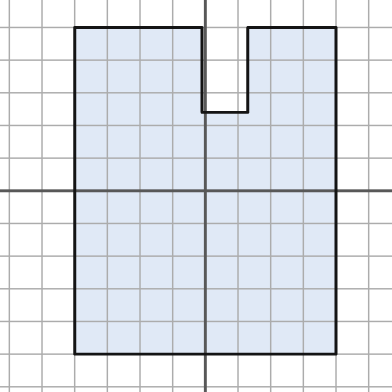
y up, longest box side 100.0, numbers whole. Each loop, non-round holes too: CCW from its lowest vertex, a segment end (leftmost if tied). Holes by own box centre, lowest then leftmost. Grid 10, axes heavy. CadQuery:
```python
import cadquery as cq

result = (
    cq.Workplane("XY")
    .moveTo(-40.0, -50.0)
    .lineTo(40.0, -50.0)
    .lineTo(40.0, 50.0)
    .lineTo(13.0, 50.0)
    .lineTo(13.0, 24.0)
    .lineTo(-1.0, 24.0)
    .lineTo(-1.0, 50.0)
    .lineTo(-40.0, 50.0)
    .close()
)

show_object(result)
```